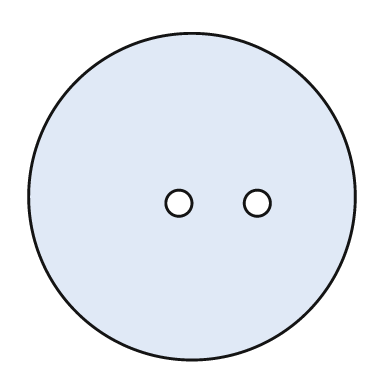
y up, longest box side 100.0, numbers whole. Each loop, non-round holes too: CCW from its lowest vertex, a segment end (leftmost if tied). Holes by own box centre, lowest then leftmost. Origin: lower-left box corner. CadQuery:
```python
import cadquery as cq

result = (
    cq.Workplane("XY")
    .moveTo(50.0, 50.0)
    .circle(50.0)
    .moveTo(46.0, 48.0)
    .circle(4.0)
    .moveTo(70.0, 48.0)
    .circle(4.0)
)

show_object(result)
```